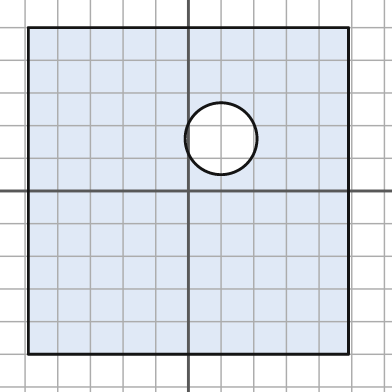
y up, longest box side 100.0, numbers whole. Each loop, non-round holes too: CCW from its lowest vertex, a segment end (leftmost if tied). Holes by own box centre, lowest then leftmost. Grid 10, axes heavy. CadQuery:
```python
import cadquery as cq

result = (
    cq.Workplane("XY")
    .moveTo(-49.0, -50.0)
    .lineTo(49.0, -50.0)
    .lineTo(49.0, 50.0)
    .lineTo(-49.0, 50.0)
    .close()
    .moveTo(10.0, 16.0)
    .circle(11.0)
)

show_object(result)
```